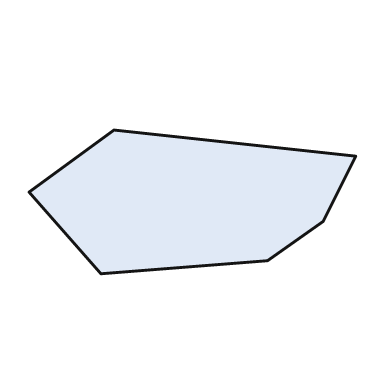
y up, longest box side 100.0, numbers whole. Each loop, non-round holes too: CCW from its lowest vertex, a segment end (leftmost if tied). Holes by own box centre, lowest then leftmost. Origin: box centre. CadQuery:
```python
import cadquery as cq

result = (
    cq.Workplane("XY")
    .moveTo(-28.0, -22.0)
    .lineTo(23.0, -18.0)
    .lineTo(40.0, -6.0)
    .lineTo(50.0, 14.0)
    .lineTo(-24.0, 22.0)
    .lineTo(-50.0, 3.0)
    .close()
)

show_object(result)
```